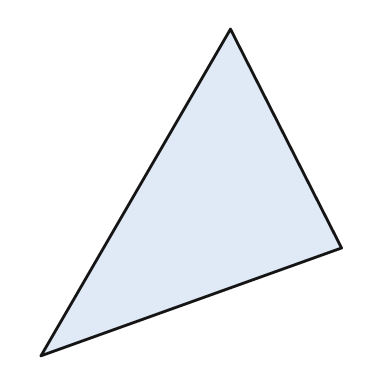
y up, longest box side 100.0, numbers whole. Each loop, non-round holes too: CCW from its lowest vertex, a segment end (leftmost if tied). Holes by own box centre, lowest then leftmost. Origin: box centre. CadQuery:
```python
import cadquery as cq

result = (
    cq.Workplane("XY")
    .moveTo(-46.0, -50.0)
    .lineTo(46.0, -17.0)
    .lineTo(12.0, 50.0)
    .close()
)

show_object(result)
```